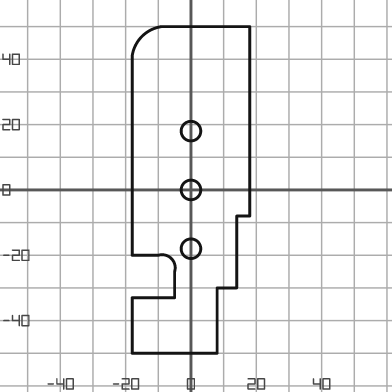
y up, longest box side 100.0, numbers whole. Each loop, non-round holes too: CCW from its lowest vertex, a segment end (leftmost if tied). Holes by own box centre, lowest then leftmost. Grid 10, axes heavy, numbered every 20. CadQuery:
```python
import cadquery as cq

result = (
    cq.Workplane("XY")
    .moveTo(-18.0, -50.0)
    .lineTo(8.0, -50.0)
    .lineTo(8.0, -30.0)
    .lineTo(14.0, -30.0)
    .lineTo(14.0, -8.0)
    .lineTo(18.0, -8.0)
    .lineTo(18.0, 50.0)
    .lineTo(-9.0, 50.0)
    .threePointArc((-15.0, 47.0), (-18.0, 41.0))
    .lineTo(-18.0, -20.0)
    .lineTo(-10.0, -20.0)
    .threePointArc((-6.0, -21.0), (-5.0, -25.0))
    .lineTo(-5.0, -33.0)
    .lineTo(-18.0, -33.0)
    .close()
    .moveTo(0.0, -18.0)
    .circle(3.0)
    .moveTo(0.0, 0.0)
    .circle(3.0)
    .moveTo(0.0, 18.0)
    .circle(3.0)
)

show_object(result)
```